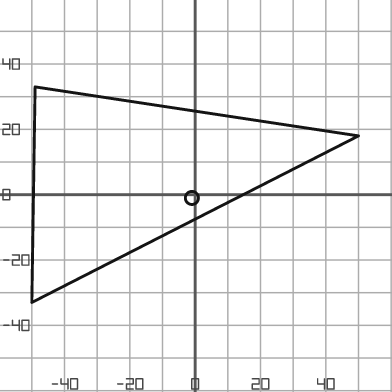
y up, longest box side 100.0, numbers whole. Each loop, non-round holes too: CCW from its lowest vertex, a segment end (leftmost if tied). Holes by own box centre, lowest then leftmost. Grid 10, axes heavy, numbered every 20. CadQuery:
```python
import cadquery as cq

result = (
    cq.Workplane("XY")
    .moveTo(-50.0, -33.0)
    .lineTo(50.0, 18.0)
    .lineTo(-49.0, 33.0)
    .close()
    .moveTo(-1.0, -1.0)
    .circle(2.0)
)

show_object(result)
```